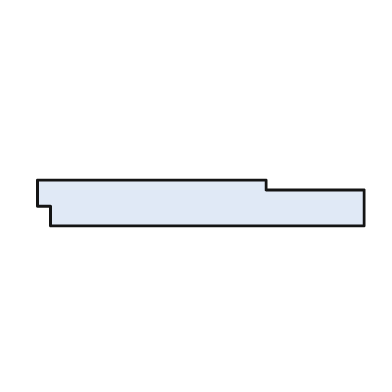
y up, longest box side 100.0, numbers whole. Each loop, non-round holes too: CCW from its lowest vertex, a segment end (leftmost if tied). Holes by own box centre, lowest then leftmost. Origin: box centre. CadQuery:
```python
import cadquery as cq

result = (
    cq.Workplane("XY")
    .moveTo(-46.0, -7.0)
    .lineTo(50.0, -7.0)
    .lineTo(50.0, 4.0)
    .lineTo(20.0, 4.0)
    .lineTo(20.0, 7.0)
    .lineTo(-50.0, 7.0)
    .lineTo(-50.0, -1.0)
    .lineTo(-46.0, -1.0)
    .close()
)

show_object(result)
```